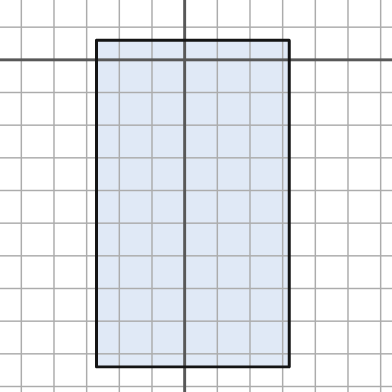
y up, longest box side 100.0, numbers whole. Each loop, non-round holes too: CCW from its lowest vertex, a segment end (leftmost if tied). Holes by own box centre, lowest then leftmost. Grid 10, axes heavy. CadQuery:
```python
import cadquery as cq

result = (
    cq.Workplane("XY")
    .moveTo(-27.0, -94.0)
    .lineTo(32.0, -94.0)
    .lineTo(32.0, 6.0)
    .lineTo(-27.0, 6.0)
    .close()
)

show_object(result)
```